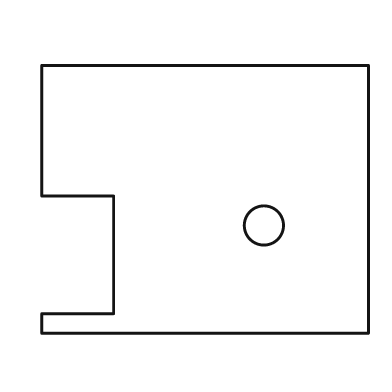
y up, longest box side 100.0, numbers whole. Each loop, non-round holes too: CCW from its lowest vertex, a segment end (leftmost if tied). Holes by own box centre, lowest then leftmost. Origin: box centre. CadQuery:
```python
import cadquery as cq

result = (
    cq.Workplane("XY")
    .moveTo(-50.0, -41.0)
    .lineTo(50.0, -41.0)
    .lineTo(50.0, 41.0)
    .lineTo(-50.0, 41.0)
    .lineTo(-50.0, 1.0)
    .lineTo(-28.0, 1.0)
    .lineTo(-28.0, -35.0)
    .lineTo(-50.0, -35.0)
    .close()
    .moveTo(18.0, -8.0)
    .circle(6.0)
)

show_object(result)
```